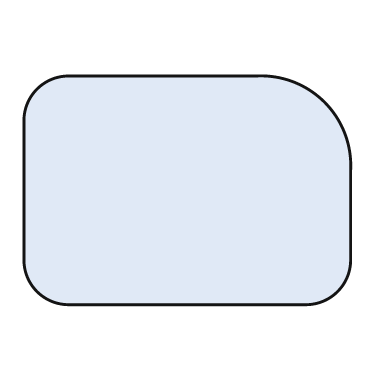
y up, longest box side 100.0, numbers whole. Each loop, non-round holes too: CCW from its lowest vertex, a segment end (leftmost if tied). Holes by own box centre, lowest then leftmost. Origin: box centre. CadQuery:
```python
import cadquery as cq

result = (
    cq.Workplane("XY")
    .moveTo(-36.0, -35.0)
    .lineTo(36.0, -35.0)
    .threePointArc((46.0, -31.0), (50.0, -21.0))
    .lineTo(50.0, 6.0)
    .threePointArc((42.0, 27.0), (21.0, 35.0))
    .lineTo(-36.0, 35.0)
    .threePointArc((-46.0, 31.0), (-50.0, 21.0))
    .lineTo(-50.0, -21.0)
    .threePointArc((-46.0, -31.0), (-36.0, -35.0))
    .close()
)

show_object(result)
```